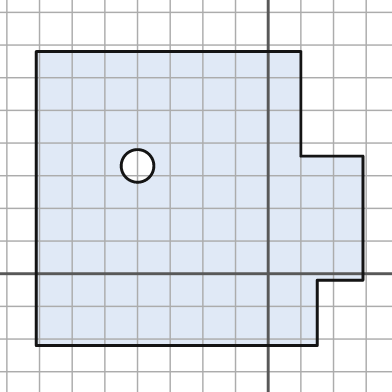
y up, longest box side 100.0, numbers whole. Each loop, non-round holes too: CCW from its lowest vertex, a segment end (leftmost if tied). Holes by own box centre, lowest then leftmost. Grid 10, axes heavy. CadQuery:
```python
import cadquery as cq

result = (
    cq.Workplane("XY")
    .moveTo(-71.0, -22.0)
    .lineTo(15.0, -22.0)
    .lineTo(15.0, -2.0)
    .lineTo(29.0, -2.0)
    .lineTo(29.0, 36.0)
    .lineTo(10.0, 36.0)
    .lineTo(10.0, 68.0)
    .lineTo(-71.0, 68.0)
    .close()
    .moveTo(-40.0, 33.0)
    .circle(5.0)
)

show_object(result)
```